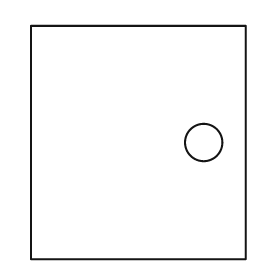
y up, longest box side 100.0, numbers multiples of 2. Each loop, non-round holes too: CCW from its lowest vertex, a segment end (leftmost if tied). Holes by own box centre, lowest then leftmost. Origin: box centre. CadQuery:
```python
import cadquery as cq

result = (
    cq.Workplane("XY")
    .moveTo(-46.0, -50.0)
    .lineTo(46.0, -50.0)
    .lineTo(46.0, 50.0)
    .lineTo(-46.0, 50.0)
    .close()
    .moveTo(28.0, 0.0)
    .circle(8.0)
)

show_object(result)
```